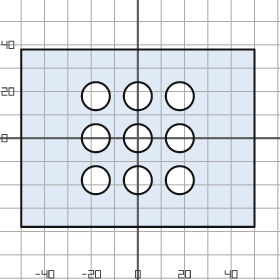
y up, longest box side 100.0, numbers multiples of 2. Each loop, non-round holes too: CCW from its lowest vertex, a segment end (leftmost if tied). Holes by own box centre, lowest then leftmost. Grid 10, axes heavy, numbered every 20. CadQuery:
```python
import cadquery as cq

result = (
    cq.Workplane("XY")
    .moveTo(-50.0, -38.0)
    .lineTo(50.0, -38.0)
    .lineTo(50.0, 38.0)
    .lineTo(-50.0, 38.0)
    .close()
    .moveTo(-18.0, -18.0)
    .circle(6.0)
    .moveTo(0.0, -18.0)
    .circle(6.0)
    .moveTo(18.0, -18.0)
    .circle(6.0)
    .moveTo(-18.0, 0.0)
    .circle(6.0)
    .moveTo(0.0, 0.0)
    .circle(6.0)
    .moveTo(18.0, 0.0)
    .circle(6.0)
    .moveTo(-18.0, 18.0)
    .circle(6.0)
    .moveTo(0.0, 18.0)
    .circle(6.0)
    .moveTo(18.0, 18.0)
    .circle(6.0)
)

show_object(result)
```